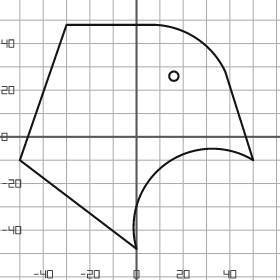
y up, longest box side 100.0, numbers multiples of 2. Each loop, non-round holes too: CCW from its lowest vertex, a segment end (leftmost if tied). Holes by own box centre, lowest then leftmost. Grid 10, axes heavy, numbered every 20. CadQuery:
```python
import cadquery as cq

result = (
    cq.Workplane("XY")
    .moveTo(0.0, -48.0)
    .threePointArc((12.0, -12.0), (50.0, -10.0))
    .lineTo(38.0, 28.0)
    .threePointArc((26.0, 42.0), (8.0, 48.0))
    .lineTo(-30.0, 48.0)
    .lineTo(-50.0, -10.0)
    .close()
    .moveTo(16.0, 26.0)
    .circle(2.0)
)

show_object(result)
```